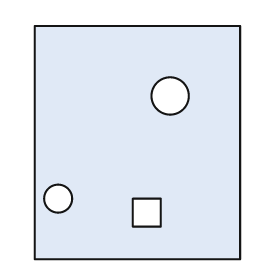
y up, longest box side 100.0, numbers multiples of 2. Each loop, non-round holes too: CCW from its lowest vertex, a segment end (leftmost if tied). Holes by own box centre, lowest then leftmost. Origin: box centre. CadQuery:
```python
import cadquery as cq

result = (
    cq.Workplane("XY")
    .moveTo(-44.0, -50.0)
    .lineTo(44.0, -50.0)
    .lineTo(44.0, 50.0)
    .lineTo(-44.0, 50.0)
    .close()
    .moveTo(-2.0, -36.0)
    .lineTo(10.0, -36.0)
    .lineTo(10.0, -24.0)
    .lineTo(-2.0, -24.0)
    .close()
    .moveTo(-34.0, -24.0)
    .circle(6.0)
    .moveTo(14.0, 20.0)
    .circle(8.0)
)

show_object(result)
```